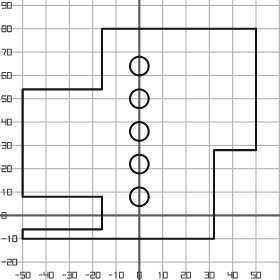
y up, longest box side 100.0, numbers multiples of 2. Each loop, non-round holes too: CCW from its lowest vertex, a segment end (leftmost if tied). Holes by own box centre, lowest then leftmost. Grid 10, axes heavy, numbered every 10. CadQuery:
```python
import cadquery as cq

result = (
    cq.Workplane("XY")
    .moveTo(-50.0, -10.0)
    .lineTo(32.0, -10.0)
    .lineTo(32.0, 28.0)
    .lineTo(50.0, 28.0)
    .lineTo(50.0, 80.0)
    .lineTo(-16.0, 80.0)
    .lineTo(-16.0, 54.0)
    .lineTo(-50.0, 54.0)
    .lineTo(-50.0, 8.0)
    .lineTo(-16.0, 8.0)
    .lineTo(-16.0, -6.0)
    .lineTo(-50.0, -6.0)
    .close()
    .moveTo(0.0, 8.0)
    .circle(4.0)
    .moveTo(0.0, 22.0)
    .circle(4.0)
    .moveTo(0.0, 36.0)
    .circle(4.0)
    .moveTo(0.0, 50.0)
    .circle(4.0)
    .moveTo(0.0, 64.0)
    .circle(4.0)
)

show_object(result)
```